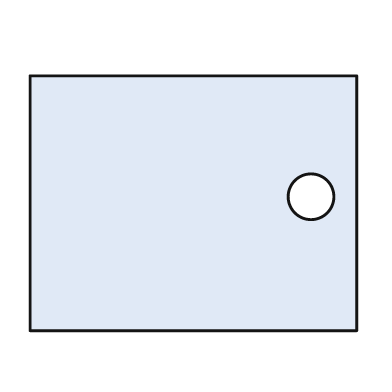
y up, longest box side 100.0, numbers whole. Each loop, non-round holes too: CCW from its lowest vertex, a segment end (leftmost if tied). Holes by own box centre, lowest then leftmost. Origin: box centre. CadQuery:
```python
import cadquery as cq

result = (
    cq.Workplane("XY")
    .moveTo(-50.0, -39.0)
    .lineTo(50.0, -39.0)
    .lineTo(50.0, 39.0)
    .lineTo(-50.0, 39.0)
    .close()
    .moveTo(36.0, 2.0)
    .circle(7.0)
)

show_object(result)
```